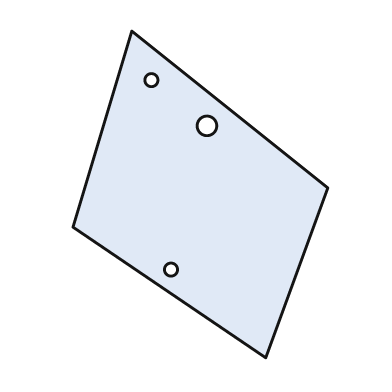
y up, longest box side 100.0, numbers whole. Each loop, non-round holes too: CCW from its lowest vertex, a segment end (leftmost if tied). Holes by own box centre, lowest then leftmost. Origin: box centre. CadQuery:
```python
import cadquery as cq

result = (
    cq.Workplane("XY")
    .moveTo(20.0, -50.0)
    .lineTo(39.0, 2.0)
    .lineTo(-21.0, 50.0)
    .lineTo(-39.0, -10.0)
    .close()
    .moveTo(-9.0, -23.0)
    .circle(2.0)
    .moveTo(2.0, 21.0)
    .circle(3.0)
    .moveTo(-15.0, 35.0)
    .circle(2.0)
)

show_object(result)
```